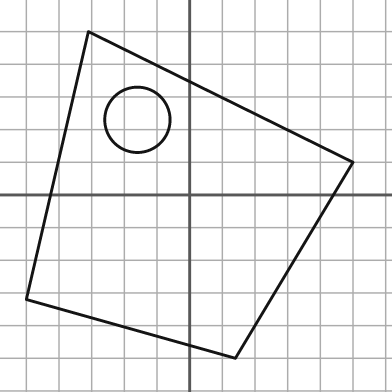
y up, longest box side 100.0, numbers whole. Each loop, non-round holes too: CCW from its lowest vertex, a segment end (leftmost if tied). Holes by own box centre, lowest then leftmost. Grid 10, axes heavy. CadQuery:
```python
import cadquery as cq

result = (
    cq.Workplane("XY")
    .moveTo(14.0, -50.0)
    .lineTo(50.0, 10.0)
    .lineTo(-31.0, 50.0)
    .lineTo(-50.0, -32.0)
    .close()
    .moveTo(-16.0, 23.0)
    .circle(10.0)
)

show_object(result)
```